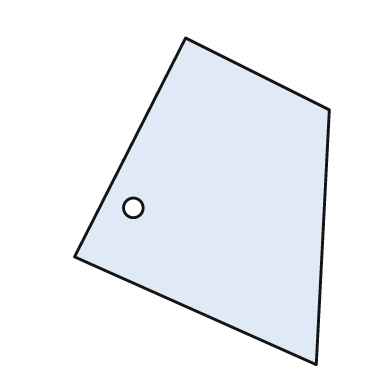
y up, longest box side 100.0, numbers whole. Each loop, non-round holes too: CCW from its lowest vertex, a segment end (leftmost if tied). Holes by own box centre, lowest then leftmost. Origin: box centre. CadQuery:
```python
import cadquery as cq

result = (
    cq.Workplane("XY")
    .moveTo(35.0, -50.0)
    .lineTo(39.0, 28.0)
    .lineTo(-5.0, 50.0)
    .lineTo(-39.0, -17.0)
    .close()
    .moveTo(-21.0, -2.0)
    .circle(3.0)
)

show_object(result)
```